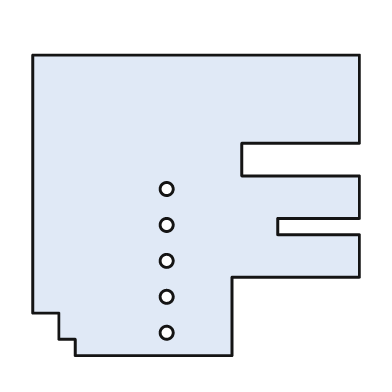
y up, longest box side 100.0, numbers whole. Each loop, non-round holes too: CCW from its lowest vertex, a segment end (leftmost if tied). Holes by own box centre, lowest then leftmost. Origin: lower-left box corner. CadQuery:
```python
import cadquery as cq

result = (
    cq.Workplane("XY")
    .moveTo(13.0, 0.0)
    .lineTo(61.0, 0.0)
    .lineTo(61.0, 24.0)
    .lineTo(100.0, 24.0)
    .lineTo(100.0, 37.0)
    .lineTo(75.0, 37.0)
    .lineTo(75.0, 42.0)
    .lineTo(100.0, 42.0)
    .lineTo(100.0, 55.0)
    .lineTo(64.0, 55.0)
    .lineTo(64.0, 65.0)
    .lineTo(100.0, 65.0)
    .lineTo(100.0, 92.0)
    .lineTo(0.0, 92.0)
    .lineTo(0.0, 13.0)
    .lineTo(8.0, 13.0)
    .lineTo(8.0, 5.0)
    .lineTo(13.0, 5.0)
    .close()
    .moveTo(41.0, 7.0)
    .circle(2.0)
    .moveTo(41.0, 18.0)
    .circle(2.0)
    .moveTo(41.0, 29.0)
    .circle(2.0)
    .moveTo(41.0, 40.0)
    .circle(2.0)
    .moveTo(41.0, 51.0)
    .circle(2.0)
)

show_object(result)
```